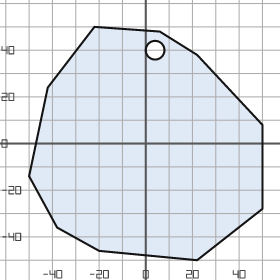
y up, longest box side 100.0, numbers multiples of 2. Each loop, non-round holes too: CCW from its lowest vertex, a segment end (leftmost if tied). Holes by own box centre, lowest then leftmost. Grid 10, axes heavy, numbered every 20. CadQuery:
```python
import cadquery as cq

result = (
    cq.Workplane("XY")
    .moveTo(22.0, -50.0)
    .lineTo(50.0, -28.0)
    .lineTo(50.0, 8.0)
    .lineTo(22.0, 38.0)
    .lineTo(6.0, 48.0)
    .lineTo(-22.0, 50.0)
    .lineTo(-42.0, 24.0)
    .lineTo(-50.0, -14.0)
    .lineTo(-38.0, -36.0)
    .lineTo(-20.0, -46.0)
    .close()
    .moveTo(4.0, 40.0)
    .circle(4.0)
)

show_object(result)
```